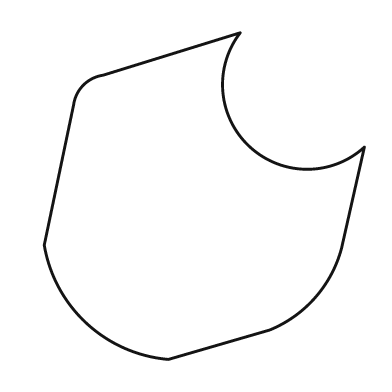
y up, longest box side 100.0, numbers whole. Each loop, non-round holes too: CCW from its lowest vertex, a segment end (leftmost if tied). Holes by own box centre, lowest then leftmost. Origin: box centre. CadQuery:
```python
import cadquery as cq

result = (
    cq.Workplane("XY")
    .moveTo(-11.0, -50.0)
    .lineTo(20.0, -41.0)
    .threePointArc((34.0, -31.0), (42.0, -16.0))
    .lineTo(49.0, 15.0)
    .threePointArc((14.0, 15.0), (11.0, 50.0))
    .lineTo(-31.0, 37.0)
    .threePointArc((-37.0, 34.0), (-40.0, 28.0))
    .lineTo(-49.0, -15.0)
    .threePointArc((-36.0, -39.0), (-11.0, -50.0))
    .close()
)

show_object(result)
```